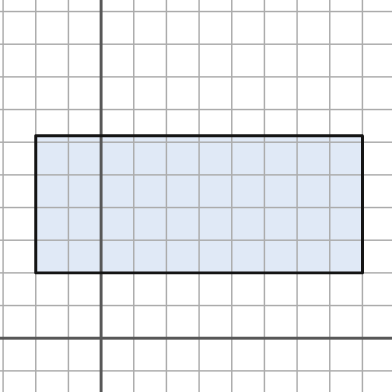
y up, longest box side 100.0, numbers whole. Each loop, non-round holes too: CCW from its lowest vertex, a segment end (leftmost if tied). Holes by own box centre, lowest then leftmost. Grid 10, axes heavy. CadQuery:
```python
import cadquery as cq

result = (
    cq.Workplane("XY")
    .moveTo(-20.0, 20.0)
    .lineTo(80.0, 20.0)
    .lineTo(80.0, 62.0)
    .lineTo(-20.0, 62.0)
    .close()
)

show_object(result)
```